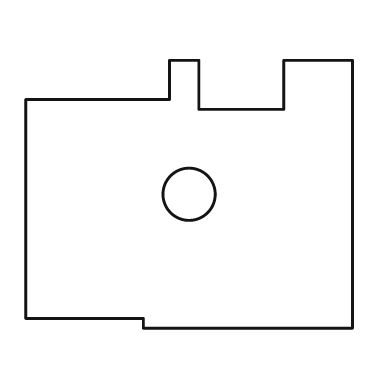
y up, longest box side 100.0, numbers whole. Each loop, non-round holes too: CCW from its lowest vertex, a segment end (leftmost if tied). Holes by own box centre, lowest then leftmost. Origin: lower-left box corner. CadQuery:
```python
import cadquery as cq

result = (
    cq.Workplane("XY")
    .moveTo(36.0, 0.0)
    .lineTo(100.0, 0.0)
    .lineTo(100.0, 82.0)
    .lineTo(79.0, 82.0)
    .lineTo(79.0, 67.0)
    .lineTo(53.0, 67.0)
    .lineTo(53.0, 82.0)
    .lineTo(44.0, 82.0)
    .lineTo(44.0, 70.0)
    .lineTo(0.0, 70.0)
    .lineTo(0.0, 3.0)
    .lineTo(36.0, 3.0)
    .close()
    .moveTo(50.0, 41.0)
    .circle(8.0)
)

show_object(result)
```